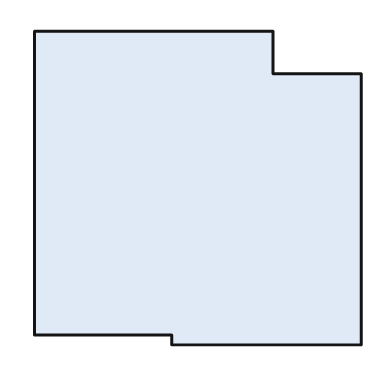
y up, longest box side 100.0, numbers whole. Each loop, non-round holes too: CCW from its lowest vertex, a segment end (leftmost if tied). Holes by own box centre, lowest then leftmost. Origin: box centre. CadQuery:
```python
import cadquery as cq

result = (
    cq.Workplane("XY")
    .moveTo(-8.0, -48.0)
    .lineTo(50.0, -48.0)
    .lineTo(50.0, 35.0)
    .lineTo(23.0, 35.0)
    .lineTo(23.0, 48.0)
    .lineTo(-50.0, 48.0)
    .lineTo(-50.0, -45.0)
    .lineTo(-8.0, -45.0)
    .close()
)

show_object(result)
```